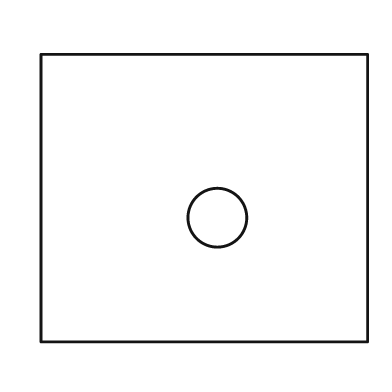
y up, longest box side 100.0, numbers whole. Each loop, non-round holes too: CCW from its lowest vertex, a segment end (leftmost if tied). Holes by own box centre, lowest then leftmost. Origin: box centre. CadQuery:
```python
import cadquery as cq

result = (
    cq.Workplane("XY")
    .moveTo(-50.0, -44.0)
    .lineTo(50.0, -44.0)
    .lineTo(50.0, 44.0)
    .lineTo(-50.0, 44.0)
    .close()
    .moveTo(4.0, -6.0)
    .circle(9.0)
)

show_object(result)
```